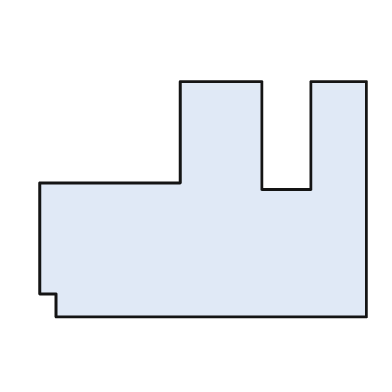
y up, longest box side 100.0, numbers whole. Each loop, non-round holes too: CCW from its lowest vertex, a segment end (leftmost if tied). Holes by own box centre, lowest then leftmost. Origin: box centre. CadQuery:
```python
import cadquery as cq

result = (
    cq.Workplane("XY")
    .moveTo(-45.0, -36.0)
    .lineTo(50.0, -36.0)
    .lineTo(50.0, 36.0)
    .lineTo(33.0, 36.0)
    .lineTo(33.0, 3.0)
    .lineTo(18.0, 3.0)
    .lineTo(18.0, 36.0)
    .lineTo(-7.0, 36.0)
    .lineTo(-7.0, 5.0)
    .lineTo(-50.0, 5.0)
    .lineTo(-50.0, -29.0)
    .lineTo(-45.0, -29.0)
    .close()
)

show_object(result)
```